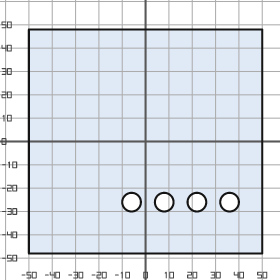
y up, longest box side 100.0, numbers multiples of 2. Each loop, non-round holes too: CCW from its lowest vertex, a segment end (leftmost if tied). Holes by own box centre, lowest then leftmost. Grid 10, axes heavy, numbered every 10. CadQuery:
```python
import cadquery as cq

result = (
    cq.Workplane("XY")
    .moveTo(-50.0, -48.0)
    .lineTo(50.0, -48.0)
    .lineTo(50.0, 48.0)
    .lineTo(-50.0, 48.0)
    .close()
    .moveTo(-6.0, -26.0)
    .circle(4.0)
    .moveTo(8.0, -26.0)
    .circle(4.0)
    .moveTo(22.0, -26.0)
    .circle(4.0)
    .moveTo(36.0, -26.0)
    .circle(4.0)
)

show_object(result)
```